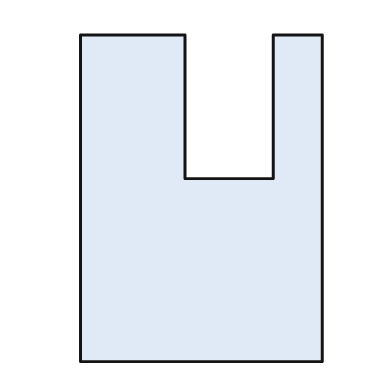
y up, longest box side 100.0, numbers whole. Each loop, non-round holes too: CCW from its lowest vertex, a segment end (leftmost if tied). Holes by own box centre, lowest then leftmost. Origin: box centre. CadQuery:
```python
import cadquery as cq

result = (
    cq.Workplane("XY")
    .moveTo(-37.0, -50.0)
    .lineTo(37.0, -50.0)
    .lineTo(37.0, 50.0)
    .lineTo(22.0, 50.0)
    .lineTo(22.0, 6.0)
    .lineTo(-5.0, 6.0)
    .lineTo(-5.0, 50.0)
    .lineTo(-37.0, 50.0)
    .close()
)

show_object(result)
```